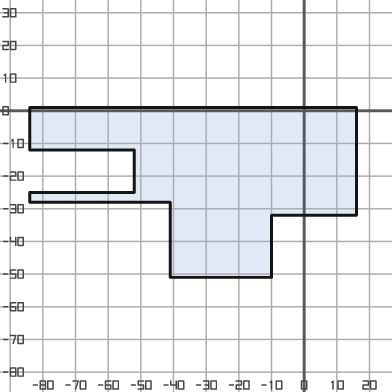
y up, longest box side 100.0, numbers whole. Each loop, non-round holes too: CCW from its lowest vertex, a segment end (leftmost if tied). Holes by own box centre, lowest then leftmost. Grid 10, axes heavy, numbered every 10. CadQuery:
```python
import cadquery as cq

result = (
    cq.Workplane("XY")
    .moveTo(-41.0, -51.0)
    .lineTo(-10.0, -51.0)
    .lineTo(-10.0, -32.0)
    .lineTo(16.0, -32.0)
    .lineTo(16.0, 1.0)
    .lineTo(-84.0, 1.0)
    .lineTo(-84.0, -12.0)
    .lineTo(-52.0, -12.0)
    .lineTo(-52.0, -25.0)
    .lineTo(-84.0, -25.0)
    .lineTo(-84.0, -28.0)
    .lineTo(-41.0, -28.0)
    .close()
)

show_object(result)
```